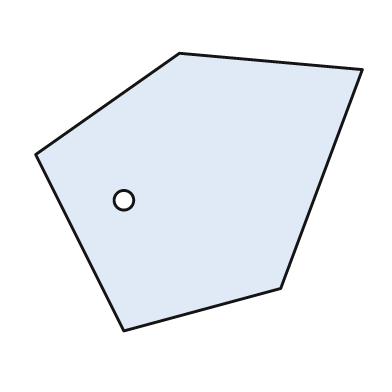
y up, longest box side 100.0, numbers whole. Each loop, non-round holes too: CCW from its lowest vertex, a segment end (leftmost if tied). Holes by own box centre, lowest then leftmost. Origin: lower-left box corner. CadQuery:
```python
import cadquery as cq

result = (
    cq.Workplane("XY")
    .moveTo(27.0, 0.0)
    .lineTo(75.0, 13.0)
    .lineTo(100.0, 80.0)
    .lineTo(44.0, 85.0)
    .lineTo(0.0, 54.0)
    .close()
    .moveTo(27.0, 40.0)
    .circle(3.0)
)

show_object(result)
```